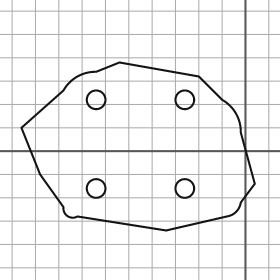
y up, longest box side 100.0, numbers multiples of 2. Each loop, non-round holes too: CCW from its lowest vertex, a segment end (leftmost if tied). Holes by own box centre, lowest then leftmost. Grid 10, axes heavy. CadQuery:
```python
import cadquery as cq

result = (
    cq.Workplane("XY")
    .moveTo(-34.0, -34.0)
    .lineTo(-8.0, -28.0)
    .threePointArc((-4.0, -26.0), (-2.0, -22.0))
    .lineTo(4.0, -14.0)
    .lineTo(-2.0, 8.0)
    .threePointArc((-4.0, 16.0), (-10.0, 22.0))
    .lineTo(-20.0, 32.0)
    .lineTo(-54.0, 38.0)
    .lineTo(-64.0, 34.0)
    .threePointArc((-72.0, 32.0), (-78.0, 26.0))
    .lineTo(-96.0, 10.0)
    .lineTo(-88.0, -10.0)
    .lineTo(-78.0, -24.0)
    .threePointArc((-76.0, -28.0), (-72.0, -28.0))
    .close()
    .moveTo(-64.0, -16.0)
    .circle(4.0)
    .moveTo(-26.0, -16.0)
    .circle(4.0)
    .moveTo(-64.0, 22.0)
    .circle(4.0)
    .moveTo(-26.0, 22.0)
    .circle(4.0)
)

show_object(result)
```